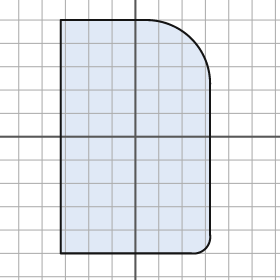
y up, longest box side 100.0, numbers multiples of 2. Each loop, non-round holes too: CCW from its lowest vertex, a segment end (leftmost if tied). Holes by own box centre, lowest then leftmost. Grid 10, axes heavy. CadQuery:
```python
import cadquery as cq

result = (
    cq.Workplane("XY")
    .moveTo(-32.0, -50.0)
    .lineTo(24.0, -50.0)
    .threePointArc((30.0, -48.0), (32.0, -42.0))
    .lineTo(32.0, 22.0)
    .threePointArc((24.0, 42.0), (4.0, 50.0))
    .lineTo(-32.0, 50.0)
    .close()
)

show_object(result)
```